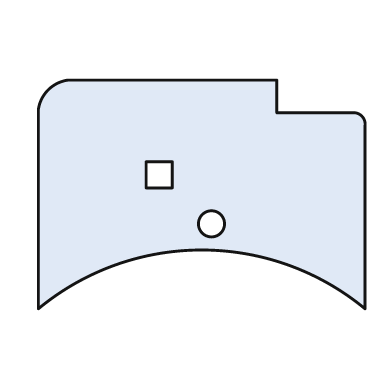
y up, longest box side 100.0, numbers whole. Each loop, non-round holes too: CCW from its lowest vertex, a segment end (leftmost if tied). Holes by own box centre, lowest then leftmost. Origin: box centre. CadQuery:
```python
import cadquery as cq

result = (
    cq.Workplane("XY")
    .moveTo(-50.0, -35.0)
    .threePointArc((0.0, -17.0), (50.0, -35.0))
    .lineTo(50.0, 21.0)
    .threePointArc((49.0, 24.0), (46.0, 25.0))
    .lineTo(23.0, 25.0)
    .lineTo(23.0, 35.0)
    .lineTo(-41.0, 35.0)
    .threePointArc((-47.0, 32.0), (-50.0, 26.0))
    .close()
    .moveTo(3.0, -9.0)
    .circle(4.0)
    .moveTo(-17.0, 2.0)
    .lineTo(-9.0, 2.0)
    .lineTo(-9.0, 10.0)
    .lineTo(-17.0, 10.0)
    .close()
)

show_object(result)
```